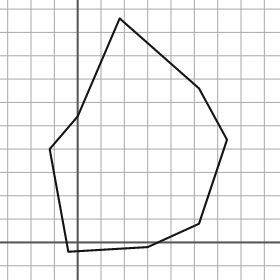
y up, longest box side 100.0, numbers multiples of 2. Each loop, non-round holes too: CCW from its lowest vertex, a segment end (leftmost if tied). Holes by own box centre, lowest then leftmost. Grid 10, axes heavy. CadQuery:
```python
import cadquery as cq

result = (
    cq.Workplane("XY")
    .moveTo(-4.0, -4.0)
    .lineTo(30.0, -2.0)
    .lineTo(52.0, 8.0)
    .lineTo(64.0, 44.0)
    .lineTo(52.0, 66.0)
    .lineTo(18.0, 96.0)
    .lineTo(0.0, 54.0)
    .lineTo(-12.0, 40.0)
    .close()
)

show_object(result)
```